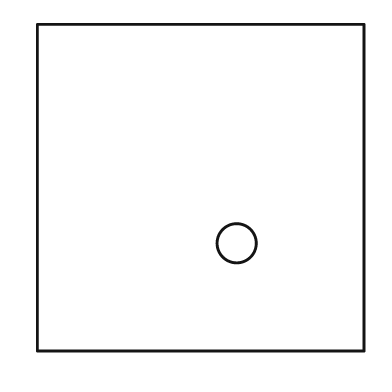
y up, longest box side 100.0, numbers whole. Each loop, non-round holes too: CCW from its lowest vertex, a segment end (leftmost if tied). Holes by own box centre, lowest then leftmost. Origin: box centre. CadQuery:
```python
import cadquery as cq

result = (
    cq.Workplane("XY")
    .moveTo(-50.0, -50.0)
    .lineTo(50.0, -50.0)
    .lineTo(50.0, 50.0)
    .lineTo(-50.0, 50.0)
    .close()
    .moveTo(11.0, -17.0)
    .circle(6.0)
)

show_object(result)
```